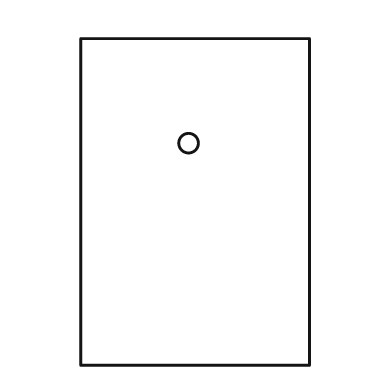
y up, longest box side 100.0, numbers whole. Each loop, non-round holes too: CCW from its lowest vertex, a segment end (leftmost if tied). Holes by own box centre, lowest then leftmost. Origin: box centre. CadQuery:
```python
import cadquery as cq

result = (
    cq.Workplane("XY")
    .moveTo(-35.0, -50.0)
    .lineTo(35.0, -50.0)
    .lineTo(35.0, 50.0)
    .lineTo(-35.0, 50.0)
    .close()
    .moveTo(-2.0, 18.0)
    .circle(3.0)
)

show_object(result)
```